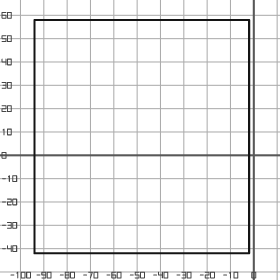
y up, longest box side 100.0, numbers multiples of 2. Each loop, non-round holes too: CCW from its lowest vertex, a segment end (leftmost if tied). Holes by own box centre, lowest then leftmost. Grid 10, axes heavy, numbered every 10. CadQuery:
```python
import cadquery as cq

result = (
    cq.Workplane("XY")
    .moveTo(-94.0, -42.0)
    .lineTo(-2.0, -42.0)
    .lineTo(-2.0, 58.0)
    .lineTo(-94.0, 58.0)
    .close()
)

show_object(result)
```